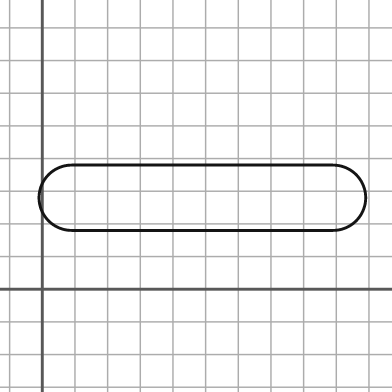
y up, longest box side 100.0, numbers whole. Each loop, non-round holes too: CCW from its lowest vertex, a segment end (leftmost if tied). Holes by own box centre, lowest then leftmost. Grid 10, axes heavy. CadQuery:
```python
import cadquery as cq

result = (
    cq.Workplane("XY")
    .moveTo(9.0, 18.0)
    .lineTo(89.0, 18.0)
    .threePointArc((99.0, 28.0), (89.0, 38.0))
    .lineTo(9.0, 38.0)
    .threePointArc((-1.0, 28.0), (9.0, 18.0))
    .close()
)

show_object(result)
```